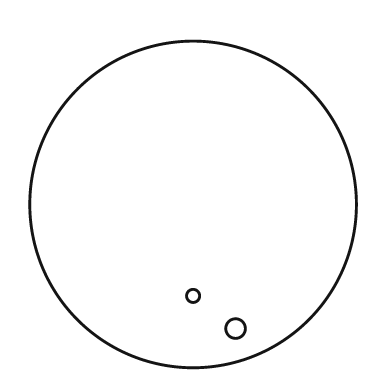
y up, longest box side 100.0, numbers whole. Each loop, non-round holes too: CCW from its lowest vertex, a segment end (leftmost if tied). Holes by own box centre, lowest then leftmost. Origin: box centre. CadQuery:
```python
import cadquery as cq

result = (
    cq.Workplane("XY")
    .moveTo(0.0, 0.0)
    .circle(50.0)
    .moveTo(13.0, -38.0)
    .circle(3.0)
    .moveTo(0.0, -28.0)
    .circle(2.0)
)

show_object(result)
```